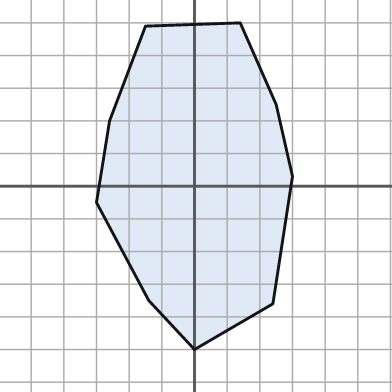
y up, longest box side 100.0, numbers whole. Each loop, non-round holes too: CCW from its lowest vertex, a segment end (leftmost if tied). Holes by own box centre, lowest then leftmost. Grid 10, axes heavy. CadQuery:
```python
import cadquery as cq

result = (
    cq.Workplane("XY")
    .moveTo(0.0, -50.0)
    .lineTo(24.0, -36.0)
    .lineTo(30.0, 3.0)
    .lineTo(25.0, 25.0)
    .lineTo(14.0, 50.0)
    .lineTo(-15.0, 49.0)
    .lineTo(-26.0, 20.0)
    .lineTo(-30.0, -5.0)
    .lineTo(-14.0, -35.0)
    .close()
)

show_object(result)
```